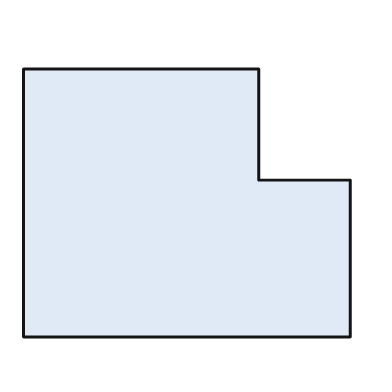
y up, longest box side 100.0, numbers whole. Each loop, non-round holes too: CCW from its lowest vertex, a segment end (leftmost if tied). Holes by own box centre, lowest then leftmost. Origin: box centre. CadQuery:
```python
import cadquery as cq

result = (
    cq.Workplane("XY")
    .moveTo(-50.0, -41.0)
    .lineTo(50.0, -41.0)
    .lineTo(50.0, 7.0)
    .lineTo(22.0, 7.0)
    .lineTo(22.0, 41.0)
    .lineTo(-50.0, 41.0)
    .close()
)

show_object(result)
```